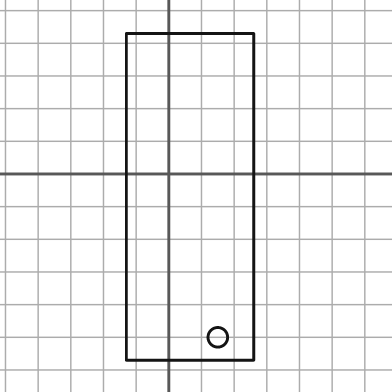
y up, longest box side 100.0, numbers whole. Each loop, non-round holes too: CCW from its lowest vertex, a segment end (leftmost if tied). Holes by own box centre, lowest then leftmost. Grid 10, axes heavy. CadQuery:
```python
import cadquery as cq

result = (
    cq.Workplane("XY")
    .moveTo(-13.0, -57.0)
    .lineTo(26.0, -57.0)
    .lineTo(26.0, 43.0)
    .lineTo(-13.0, 43.0)
    .close()
    .moveTo(15.0, -50.0)
    .circle(3.0)
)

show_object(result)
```